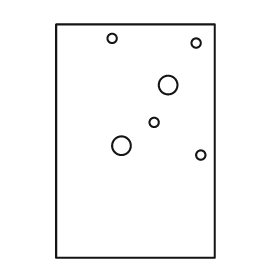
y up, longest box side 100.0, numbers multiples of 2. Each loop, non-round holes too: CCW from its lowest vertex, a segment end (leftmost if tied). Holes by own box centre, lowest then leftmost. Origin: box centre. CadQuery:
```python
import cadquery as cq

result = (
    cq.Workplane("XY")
    .moveTo(-34.0, -50.0)
    .lineTo(34.0, -50.0)
    .lineTo(34.0, 50.0)
    .lineTo(-34.0, 50.0)
    .close()
    .moveTo(28.0, -6.0)
    .circle(2.0)
    .moveTo(-6.0, -2.0)
    .circle(4.0)
    .moveTo(8.0, 8.0)
    .circle(2.0)
    .moveTo(14.0, 24.0)
    .circle(4.0)
    .moveTo(26.0, 42.0)
    .circle(2.0)
    .moveTo(-10.0, 44.0)
    .circle(2.0)
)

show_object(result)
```